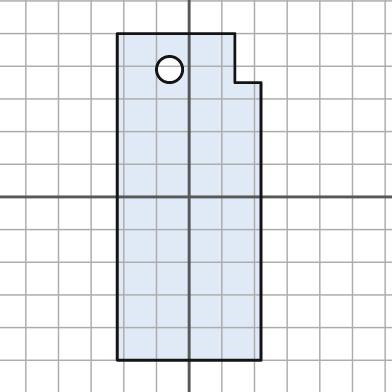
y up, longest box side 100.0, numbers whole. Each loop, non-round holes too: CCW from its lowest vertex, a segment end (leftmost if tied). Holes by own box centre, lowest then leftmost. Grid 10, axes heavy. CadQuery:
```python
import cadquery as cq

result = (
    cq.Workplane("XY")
    .moveTo(-22.0, -50.0)
    .lineTo(22.0, -50.0)
    .lineTo(22.0, 35.0)
    .lineTo(14.0, 35.0)
    .lineTo(14.0, 50.0)
    .lineTo(-22.0, 50.0)
    .close()
    .moveTo(-6.0, 39.0)
    .circle(4.0)
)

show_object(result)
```